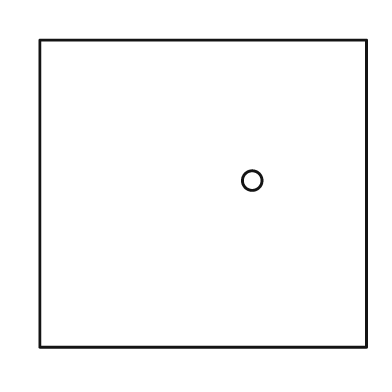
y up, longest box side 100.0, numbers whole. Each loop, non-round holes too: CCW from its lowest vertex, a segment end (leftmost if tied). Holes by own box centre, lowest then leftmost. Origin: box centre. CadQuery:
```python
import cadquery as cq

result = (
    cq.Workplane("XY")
    .moveTo(-50.0, -47.0)
    .lineTo(50.0, -47.0)
    .lineTo(50.0, 47.0)
    .lineTo(-50.0, 47.0)
    .close()
    .moveTo(15.0, 4.0)
    .circle(3.0)
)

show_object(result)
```